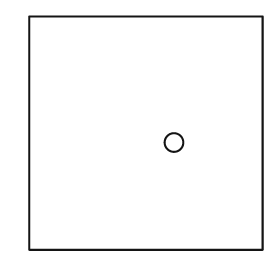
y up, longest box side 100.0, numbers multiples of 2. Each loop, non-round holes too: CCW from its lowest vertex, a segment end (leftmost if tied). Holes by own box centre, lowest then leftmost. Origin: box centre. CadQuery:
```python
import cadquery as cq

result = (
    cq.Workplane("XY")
    .moveTo(-50.0, -50.0)
    .lineTo(50.0, -50.0)
    .lineTo(50.0, 50.0)
    .lineTo(-50.0, 50.0)
    .close()
    .moveTo(12.0, -4.0)
    .circle(4.0)
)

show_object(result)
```